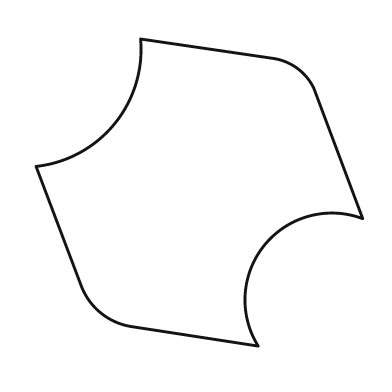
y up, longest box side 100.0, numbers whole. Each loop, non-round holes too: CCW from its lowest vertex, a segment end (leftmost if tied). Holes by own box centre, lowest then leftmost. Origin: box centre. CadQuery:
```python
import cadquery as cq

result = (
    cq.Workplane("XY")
    .moveTo(18.0, -47.0)
    .threePointArc((20.0, -16.0), (50.0, -8.0))
    .lineTo(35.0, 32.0)
    .threePointArc((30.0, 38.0), (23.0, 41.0))
    .lineTo(-18.0, 47.0)
    .threePointArc((-26.0, 21.0), (-50.0, 8.0))
    .lineTo(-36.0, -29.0)
    .threePointArc((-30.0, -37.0), (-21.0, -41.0))
    .close()
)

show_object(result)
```